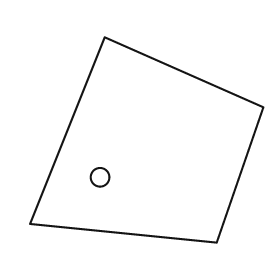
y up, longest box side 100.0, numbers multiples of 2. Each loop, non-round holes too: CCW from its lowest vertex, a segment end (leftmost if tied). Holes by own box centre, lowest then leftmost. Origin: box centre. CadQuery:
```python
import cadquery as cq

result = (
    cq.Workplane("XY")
    .moveTo(30.0, -44.0)
    .lineTo(50.0, 14.0)
    .lineTo(-18.0, 44.0)
    .lineTo(-50.0, -36.0)
    .close()
    .moveTo(-20.0, -16.0)
    .circle(4.0)
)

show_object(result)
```